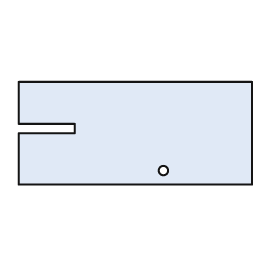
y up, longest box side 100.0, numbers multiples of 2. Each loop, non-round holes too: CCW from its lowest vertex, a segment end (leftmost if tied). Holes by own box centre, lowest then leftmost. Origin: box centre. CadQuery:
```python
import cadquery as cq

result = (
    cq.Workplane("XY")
    .moveTo(-50.0, -22.0)
    .lineTo(50.0, -22.0)
    .lineTo(50.0, 22.0)
    .lineTo(-50.0, 22.0)
    .lineTo(-50.0, 4.0)
    .lineTo(-26.0, 4.0)
    .lineTo(-26.0, 0.0)
    .lineTo(-50.0, 0.0)
    .close()
    .moveTo(12.0, -16.0)
    .circle(2.0)
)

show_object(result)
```